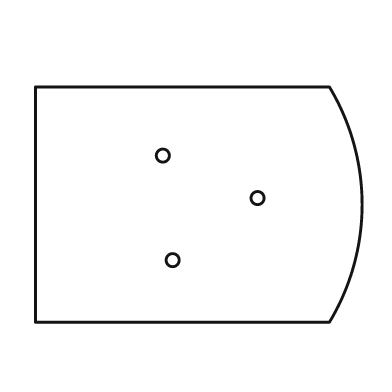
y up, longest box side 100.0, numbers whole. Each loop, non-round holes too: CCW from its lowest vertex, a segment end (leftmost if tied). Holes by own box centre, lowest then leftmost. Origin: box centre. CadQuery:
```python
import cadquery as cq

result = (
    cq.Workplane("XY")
    .moveTo(-50.0, -36.0)
    .lineTo(40.0, -36.0)
    .threePointArc((50.0, 0.0), (40.0, 36.0))
    .lineTo(-50.0, 36.0)
    .close()
    .moveTo(-8.0, -17.0)
    .circle(2.0)
    .moveTo(18.0, 2.0)
    .circle(2.0)
    .moveTo(-11.0, 15.0)
    .circle(2.0)
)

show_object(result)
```